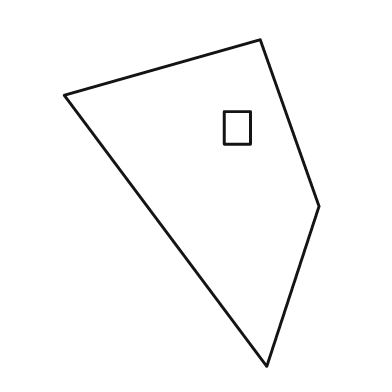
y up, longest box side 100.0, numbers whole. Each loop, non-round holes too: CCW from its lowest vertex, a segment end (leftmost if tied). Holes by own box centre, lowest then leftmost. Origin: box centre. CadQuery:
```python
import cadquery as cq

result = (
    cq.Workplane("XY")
    .moveTo(23.0, -50.0)
    .lineTo(39.0, -1.0)
    .lineTo(21.0, 50.0)
    .lineTo(-39.0, 33.0)
    .close()
    .moveTo(10.0, 18.0)
    .lineTo(18.0, 18.0)
    .lineTo(18.0, 28.0)
    .lineTo(10.0, 28.0)
    .close()
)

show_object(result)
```